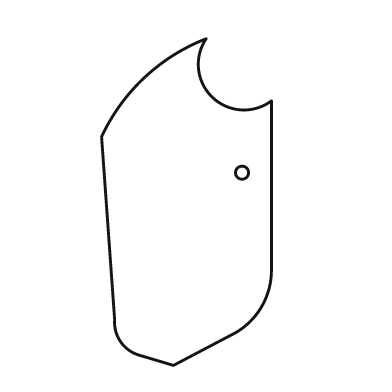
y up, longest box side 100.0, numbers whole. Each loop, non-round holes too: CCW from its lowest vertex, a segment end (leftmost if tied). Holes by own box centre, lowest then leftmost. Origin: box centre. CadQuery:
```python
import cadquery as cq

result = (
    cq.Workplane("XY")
    .moveTo(-4.0, -50.0)
    .lineTo(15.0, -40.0)
    .threePointArc((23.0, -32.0), (26.0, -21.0))
    .lineTo(26.0, 31.0)
    .threePointArc((8.0, 32.0), (6.0, 50.0))
    .threePointArc((-13.0, 38.0), (-26.0, 20.0))
    .lineTo(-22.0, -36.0)
    .threePointArc((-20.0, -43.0), (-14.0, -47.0))
    .close()
    .moveTo(17.0, 9.0)
    .circle(2.0)
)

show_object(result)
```